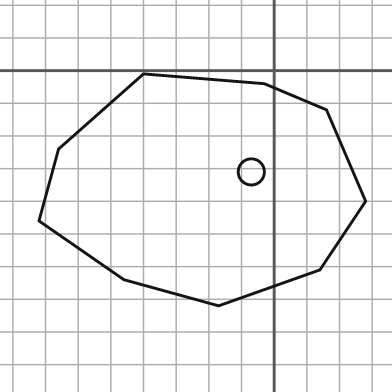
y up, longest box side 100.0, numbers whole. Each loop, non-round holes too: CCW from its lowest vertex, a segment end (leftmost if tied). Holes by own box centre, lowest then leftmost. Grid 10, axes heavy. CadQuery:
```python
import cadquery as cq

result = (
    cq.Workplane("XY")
    .moveTo(-17.0, -72.0)
    .lineTo(14.0, -61.0)
    .lineTo(28.0, -40.0)
    .lineTo(16.0, -12.0)
    .lineTo(-3.0, -4.0)
    .lineTo(-40.0, -1.0)
    .lineTo(-66.0, -24.0)
    .lineTo(-72.0, -46.0)
    .lineTo(-46.0, -64.0)
    .close()
    .moveTo(-7.0, -31.0)
    .circle(4.0)
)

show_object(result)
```